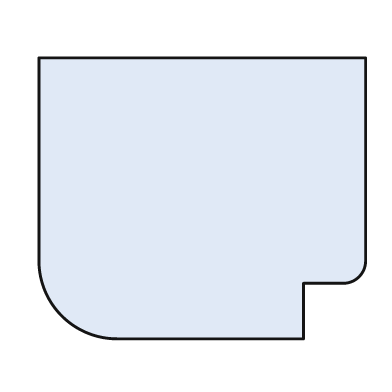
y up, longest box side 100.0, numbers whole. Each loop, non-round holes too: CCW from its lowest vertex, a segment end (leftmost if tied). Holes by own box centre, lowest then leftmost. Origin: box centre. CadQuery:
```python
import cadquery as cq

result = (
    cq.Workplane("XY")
    .moveTo(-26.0, -43.0)
    .lineTo(31.0, -43.0)
    .lineTo(31.0, -26.0)
    .lineTo(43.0, -26.0)
    .threePointArc((48.0, -24.0), (50.0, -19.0))
    .lineTo(50.0, 43.0)
    .lineTo(-50.0, 43.0)
    .lineTo(-50.0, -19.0)
    .threePointArc((-43.0, -36.0), (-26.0, -43.0))
    .close()
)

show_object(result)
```